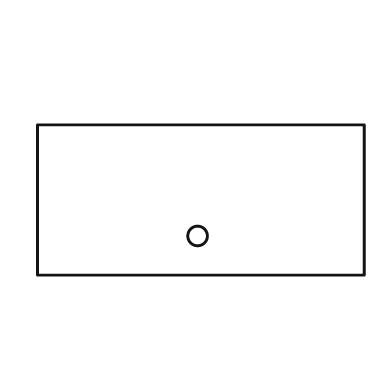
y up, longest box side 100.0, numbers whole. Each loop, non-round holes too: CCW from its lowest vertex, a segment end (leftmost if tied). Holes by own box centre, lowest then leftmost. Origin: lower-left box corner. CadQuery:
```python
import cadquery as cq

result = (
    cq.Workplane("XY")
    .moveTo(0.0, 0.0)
    .lineTo(100.0, 0.0)
    .lineTo(100.0, 46.0)
    .lineTo(0.0, 46.0)
    .close()
    .moveTo(49.0, 12.0)
    .circle(3.0)
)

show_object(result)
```